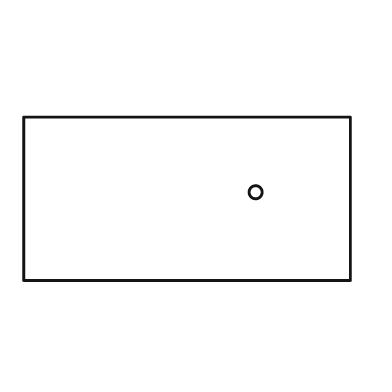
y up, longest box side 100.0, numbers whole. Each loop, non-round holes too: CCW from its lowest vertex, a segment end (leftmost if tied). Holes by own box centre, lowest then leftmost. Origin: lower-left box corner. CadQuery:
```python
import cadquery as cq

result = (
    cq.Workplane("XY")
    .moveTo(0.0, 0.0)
    .lineTo(100.0, 0.0)
    .lineTo(100.0, 50.0)
    .lineTo(0.0, 50.0)
    .close()
    .moveTo(71.0, 27.0)
    .circle(2.0)
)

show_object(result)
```